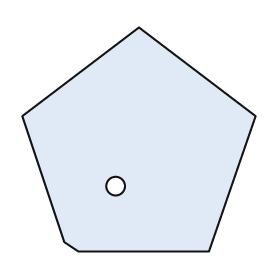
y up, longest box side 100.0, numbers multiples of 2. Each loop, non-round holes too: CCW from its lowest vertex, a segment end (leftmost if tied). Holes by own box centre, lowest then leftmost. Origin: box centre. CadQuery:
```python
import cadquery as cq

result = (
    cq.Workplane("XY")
    .moveTo(-26.0, -48.0)
    .lineTo(30.0, -48.0)
    .lineTo(50.0, 10.0)
    .lineTo(0.0, 48.0)
    .lineTo(-50.0, 10.0)
    .lineTo(-32.0, -44.0)
    .close()
    .moveTo(-10.0, -20.0)
    .circle(4.0)
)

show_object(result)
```